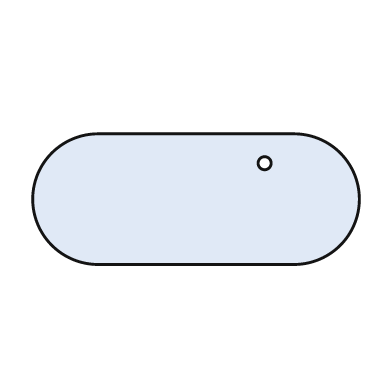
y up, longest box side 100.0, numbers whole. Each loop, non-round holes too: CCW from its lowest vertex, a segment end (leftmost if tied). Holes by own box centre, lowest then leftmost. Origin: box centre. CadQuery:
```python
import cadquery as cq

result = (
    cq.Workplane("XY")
    .moveTo(-30.0, -20.0)
    .lineTo(30.0, -20.0)
    .threePointArc((50.0, 0.0), (30.0, 20.0))
    .lineTo(-30.0, 20.0)
    .threePointArc((-50.0, 0.0), (-30.0, -20.0))
    .close()
    .moveTo(21.0, 11.0)
    .circle(2.0)
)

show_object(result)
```